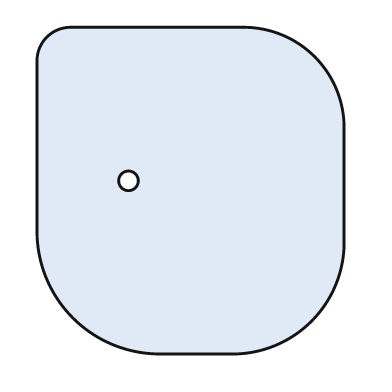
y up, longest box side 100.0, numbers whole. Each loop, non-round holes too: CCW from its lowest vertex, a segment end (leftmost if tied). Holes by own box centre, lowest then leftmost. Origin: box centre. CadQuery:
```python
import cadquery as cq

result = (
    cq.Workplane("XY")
    .moveTo(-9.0, -50.0)
    .lineTo(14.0, -50.0)
    .threePointArc((37.0, -40.0), (47.0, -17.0))
    .lineTo(47.0, 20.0)
    .threePointArc((38.0, 41.0), (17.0, 50.0))
    .lineTo(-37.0, 50.0)
    .threePointArc((-44.0, 47.0), (-47.0, 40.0))
    .lineTo(-47.0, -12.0)
    .threePointArc((-36.0, -39.0), (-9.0, -50.0))
    .close()
    .moveTo(-19.0, 3.0)
    .circle(3.0)
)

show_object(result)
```